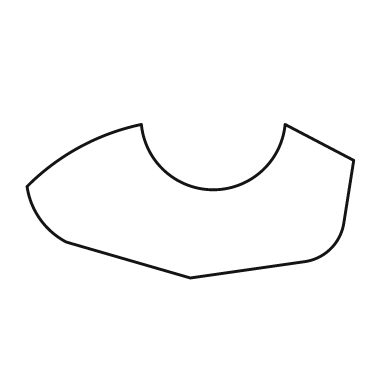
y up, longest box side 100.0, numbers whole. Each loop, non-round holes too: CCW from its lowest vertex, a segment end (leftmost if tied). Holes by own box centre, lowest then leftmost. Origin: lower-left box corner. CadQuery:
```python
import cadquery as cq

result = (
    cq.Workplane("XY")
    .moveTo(50.0, 0.0)
    .lineTo(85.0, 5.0)
    .threePointArc((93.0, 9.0), (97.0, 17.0))
    .lineTo(100.0, 36.0)
    .lineTo(79.0, 47.0)
    .threePointArc((57.0, 27.0), (35.0, 47.0))
    .threePointArc((16.0, 40.0), (0.0, 28.0))
    .threePointArc((4.0, 18.0), (12.0, 11.0))
    .close()
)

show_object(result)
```